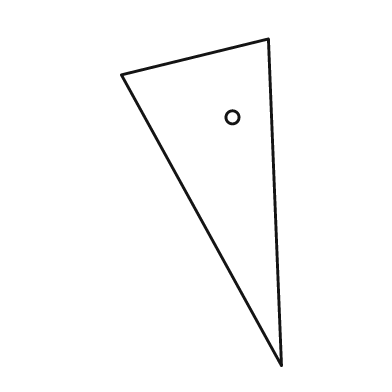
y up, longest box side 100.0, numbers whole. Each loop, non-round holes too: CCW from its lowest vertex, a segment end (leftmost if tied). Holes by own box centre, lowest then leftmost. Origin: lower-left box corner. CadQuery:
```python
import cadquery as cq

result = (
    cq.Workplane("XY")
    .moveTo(49.0, 0.0)
    .lineTo(45.0, 100.0)
    .lineTo(0.0, 89.0)
    .close()
    .moveTo(34.0, 76.0)
    .circle(2.0)
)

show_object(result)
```